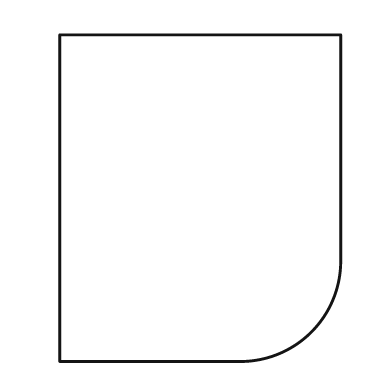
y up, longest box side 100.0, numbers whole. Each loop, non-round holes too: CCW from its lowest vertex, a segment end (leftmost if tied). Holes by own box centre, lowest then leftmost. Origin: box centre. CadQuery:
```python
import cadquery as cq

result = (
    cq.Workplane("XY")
    .moveTo(-43.0, -50.0)
    .lineTo(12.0, -50.0)
    .threePointArc((34.0, -41.0), (43.0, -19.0))
    .lineTo(43.0, 50.0)
    .lineTo(-43.0, 50.0)
    .close()
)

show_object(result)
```